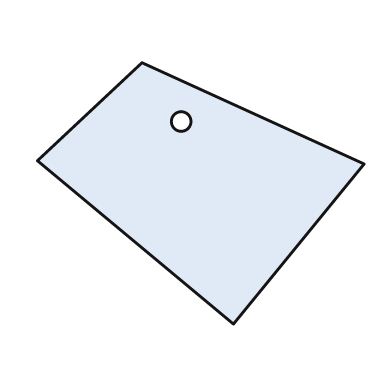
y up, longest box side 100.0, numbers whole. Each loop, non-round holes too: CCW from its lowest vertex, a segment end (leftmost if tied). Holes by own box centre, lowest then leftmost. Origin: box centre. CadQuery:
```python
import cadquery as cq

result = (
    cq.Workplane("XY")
    .moveTo(10.0, -40.0)
    .lineTo(50.0, 9.0)
    .lineTo(-18.0, 40.0)
    .lineTo(-50.0, 10.0)
    .close()
    .moveTo(-6.0, 22.0)
    .circle(3.0)
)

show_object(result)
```